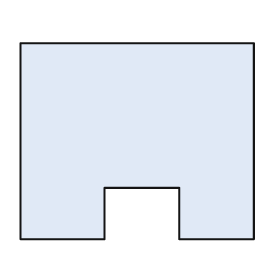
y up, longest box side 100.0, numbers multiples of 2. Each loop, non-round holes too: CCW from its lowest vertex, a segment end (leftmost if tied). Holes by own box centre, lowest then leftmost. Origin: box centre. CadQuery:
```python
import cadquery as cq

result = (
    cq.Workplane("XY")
    .moveTo(-50.0, -42.0)
    .lineTo(-14.0, -42.0)
    .lineTo(-14.0, -20.0)
    .lineTo(18.0, -20.0)
    .lineTo(18.0, -42.0)
    .lineTo(50.0, -42.0)
    .lineTo(50.0, 42.0)
    .lineTo(-50.0, 42.0)
    .close()
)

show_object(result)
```